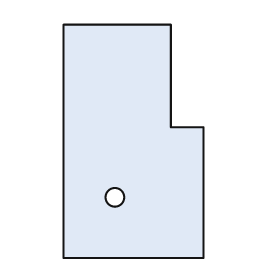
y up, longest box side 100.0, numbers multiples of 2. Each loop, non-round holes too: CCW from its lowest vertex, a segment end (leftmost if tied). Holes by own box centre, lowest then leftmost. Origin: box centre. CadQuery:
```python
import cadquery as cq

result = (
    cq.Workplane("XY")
    .moveTo(-30.0, -50.0)
    .lineTo(30.0, -50.0)
    .lineTo(30.0, 6.0)
    .lineTo(16.0, 6.0)
    .lineTo(16.0, 50.0)
    .lineTo(-30.0, 50.0)
    .close()
    .moveTo(-8.0, -24.0)
    .circle(4.0)
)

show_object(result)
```